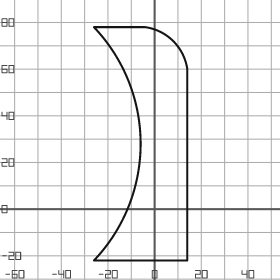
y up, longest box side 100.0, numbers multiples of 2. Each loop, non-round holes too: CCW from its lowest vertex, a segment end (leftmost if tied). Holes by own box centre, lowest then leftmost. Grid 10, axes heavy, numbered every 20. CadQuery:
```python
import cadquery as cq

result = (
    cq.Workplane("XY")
    .moveTo(-26.0, -22.0)
    .lineTo(14.0, -22.0)
    .lineTo(14.0, 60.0)
    .threePointArc((8.0, 72.0), (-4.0, 78.0))
    .lineTo(-26.0, 78.0)
    .threePointArc((-6.0, 28.0), (-26.0, -22.0))
    .close()
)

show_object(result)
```